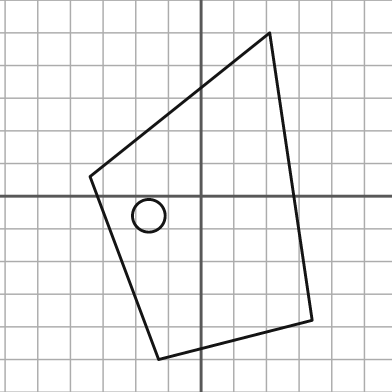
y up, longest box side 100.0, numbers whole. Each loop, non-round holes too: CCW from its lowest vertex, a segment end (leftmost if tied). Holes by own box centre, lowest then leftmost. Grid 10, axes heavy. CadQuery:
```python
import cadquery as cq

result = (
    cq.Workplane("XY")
    .moveTo(-13.0, -50.0)
    .lineTo(34.0, -38.0)
    .lineTo(21.0, 50.0)
    .lineTo(-34.0, 6.0)
    .close()
    .moveTo(-16.0, -6.0)
    .circle(5.0)
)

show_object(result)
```